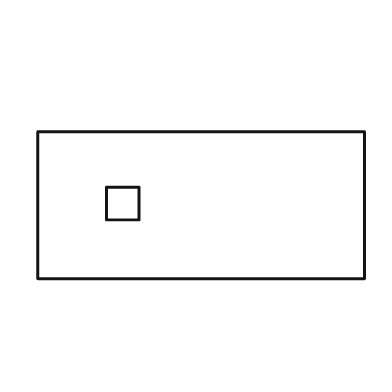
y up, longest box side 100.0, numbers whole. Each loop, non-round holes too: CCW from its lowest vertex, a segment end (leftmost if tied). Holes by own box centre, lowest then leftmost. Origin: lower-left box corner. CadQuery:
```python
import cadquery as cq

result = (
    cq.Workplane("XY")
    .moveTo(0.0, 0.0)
    .lineTo(100.0, 0.0)
    .lineTo(100.0, 45.0)
    .lineTo(0.0, 45.0)
    .close()
    .moveTo(21.0, 18.0)
    .lineTo(31.0, 18.0)
    .lineTo(31.0, 28.0)
    .lineTo(21.0, 28.0)
    .close()
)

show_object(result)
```